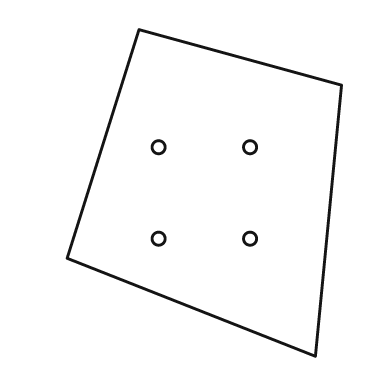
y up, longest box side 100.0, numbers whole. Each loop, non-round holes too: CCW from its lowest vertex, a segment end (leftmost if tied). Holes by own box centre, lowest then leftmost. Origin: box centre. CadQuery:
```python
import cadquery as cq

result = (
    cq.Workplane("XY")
    .moveTo(34.0, -50.0)
    .lineTo(42.0, 33.0)
    .lineTo(-20.0, 50.0)
    .lineTo(-42.0, -20.0)
    .close()
    .moveTo(-14.0, -14.0)
    .circle(2.0)
    .moveTo(14.0, -14.0)
    .circle(2.0)
    .moveTo(-14.0, 14.0)
    .circle(2.0)
    .moveTo(14.0, 14.0)
    .circle(2.0)
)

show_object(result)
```